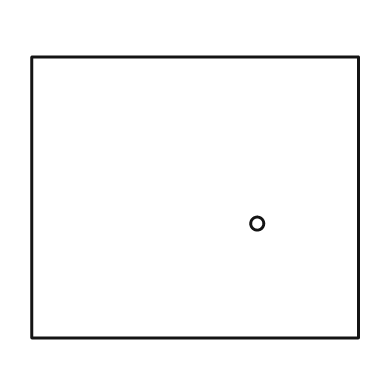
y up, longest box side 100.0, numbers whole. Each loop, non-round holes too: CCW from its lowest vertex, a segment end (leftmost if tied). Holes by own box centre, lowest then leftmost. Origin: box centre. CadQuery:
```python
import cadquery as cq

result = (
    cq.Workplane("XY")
    .moveTo(-50.0, -43.0)
    .lineTo(50.0, -43.0)
    .lineTo(50.0, 43.0)
    .lineTo(-50.0, 43.0)
    .close()
    .moveTo(19.0, -8.0)
    .circle(2.0)
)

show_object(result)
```